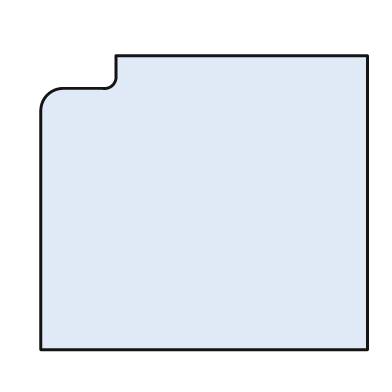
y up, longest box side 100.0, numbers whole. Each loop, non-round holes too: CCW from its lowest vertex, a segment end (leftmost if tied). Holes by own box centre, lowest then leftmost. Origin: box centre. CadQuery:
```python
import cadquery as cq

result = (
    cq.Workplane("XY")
    .moveTo(-50.0, -45.0)
    .lineTo(50.0, -45.0)
    .lineTo(50.0, 45.0)
    .lineTo(-27.0, 45.0)
    .lineTo(-27.0, 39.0)
    .threePointArc((-28.0, 36.0), (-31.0, 35.0))
    .lineTo(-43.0, 35.0)
    .threePointArc((-48.0, 33.0), (-50.0, 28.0))
    .close()
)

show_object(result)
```